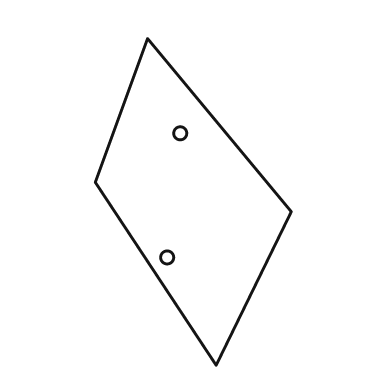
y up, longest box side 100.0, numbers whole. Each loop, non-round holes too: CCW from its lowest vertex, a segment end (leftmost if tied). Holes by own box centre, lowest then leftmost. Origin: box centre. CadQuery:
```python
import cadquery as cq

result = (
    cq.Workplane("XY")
    .moveTo(7.0, -50.0)
    .lineTo(30.0, -3.0)
    .lineTo(-14.0, 50.0)
    .lineTo(-30.0, 6.0)
    .close()
    .moveTo(-8.0, -17.0)
    .circle(2.0)
    .moveTo(-4.0, 21.0)
    .circle(2.0)
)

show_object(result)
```